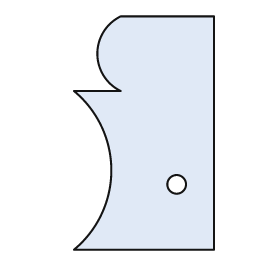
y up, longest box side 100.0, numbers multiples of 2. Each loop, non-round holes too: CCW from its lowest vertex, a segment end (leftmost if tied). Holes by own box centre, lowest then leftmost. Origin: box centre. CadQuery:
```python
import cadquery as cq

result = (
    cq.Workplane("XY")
    .moveTo(-30.0, -50.0)
    .lineTo(30.0, -50.0)
    .lineTo(30.0, 50.0)
    .lineTo(-10.0, 50.0)
    .threePointArc((-20.0, 34.0), (-10.0, 18.0))
    .lineTo(-30.0, 18.0)
    .threePointArc((-14.0, -16.0), (-30.0, -50.0))
    .close()
    .moveTo(14.0, -22.0)
    .circle(4.0)
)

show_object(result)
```